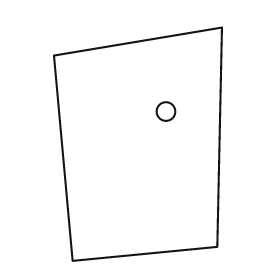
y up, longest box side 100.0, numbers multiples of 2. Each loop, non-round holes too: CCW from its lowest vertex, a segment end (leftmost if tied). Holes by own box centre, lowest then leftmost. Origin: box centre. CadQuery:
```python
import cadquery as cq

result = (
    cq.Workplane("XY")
    .moveTo(-28.0, -50.0)
    .lineTo(34.0, -44.0)
    .lineTo(36.0, 50.0)
    .lineTo(-36.0, 38.0)
    .close()
    .moveTo(12.0, 14.0)
    .circle(4.0)
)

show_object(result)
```